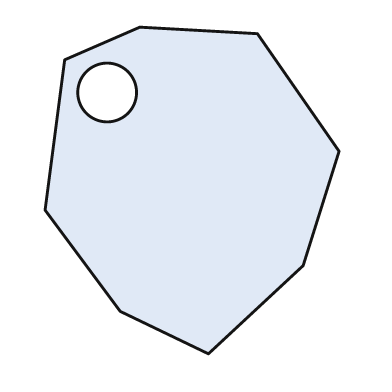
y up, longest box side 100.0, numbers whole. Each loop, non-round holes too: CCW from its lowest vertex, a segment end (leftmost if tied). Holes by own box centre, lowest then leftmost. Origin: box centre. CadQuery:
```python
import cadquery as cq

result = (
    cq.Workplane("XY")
    .moveTo(5.0, -50.0)
    .lineTo(34.0, -23.0)
    .lineTo(45.0, 12.0)
    .lineTo(20.0, 48.0)
    .lineTo(-16.0, 50.0)
    .lineTo(-39.0, 40.0)
    .lineTo(-45.0, -6.0)
    .lineTo(-22.0, -37.0)
    .close()
    .moveTo(-26.0, 30.0)
    .circle(9.0)
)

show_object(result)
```